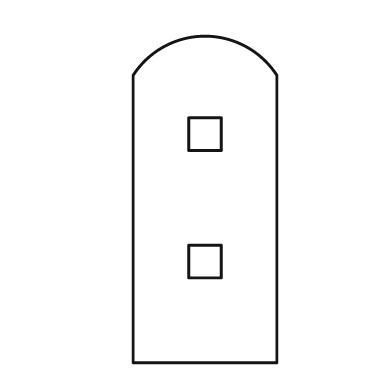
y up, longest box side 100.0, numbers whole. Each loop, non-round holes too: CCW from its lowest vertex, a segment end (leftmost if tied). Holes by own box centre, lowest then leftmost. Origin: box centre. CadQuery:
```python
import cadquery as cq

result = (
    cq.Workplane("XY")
    .moveTo(-22.0, -50.0)
    .lineTo(22.0, -50.0)
    .lineTo(22.0, 38.0)
    .threePointArc((0.0, 50.0), (-22.0, 38.0))
    .close()
    .moveTo(-5.0, -24.0)
    .lineTo(5.0, -24.0)
    .lineTo(5.0, -14.0)
    .lineTo(-5.0, -14.0)
    .close()
    .moveTo(-5.0, 15.0)
    .lineTo(5.0, 15.0)
    .lineTo(5.0, 25.0)
    .lineTo(-5.0, 25.0)
    .close()
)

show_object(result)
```